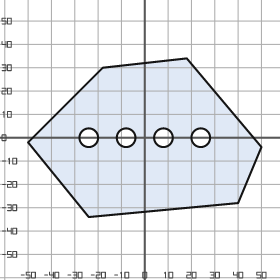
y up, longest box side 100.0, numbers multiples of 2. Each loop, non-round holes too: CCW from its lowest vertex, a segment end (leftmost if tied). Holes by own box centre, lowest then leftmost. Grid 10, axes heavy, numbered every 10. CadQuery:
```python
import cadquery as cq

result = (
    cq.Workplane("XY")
    .moveTo(-24.0, -34.0)
    .lineTo(40.0, -28.0)
    .lineTo(50.0, -4.0)
    .lineTo(18.0, 34.0)
    .lineTo(-18.0, 30.0)
    .lineTo(-50.0, -2.0)
    .close()
    .moveTo(-24.0, 0.0)
    .circle(4.0)
    .moveTo(-8.0, 0.0)
    .circle(4.0)
    .moveTo(8.0, 0.0)
    .circle(4.0)
    .moveTo(24.0, 0.0)
    .circle(4.0)
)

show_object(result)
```